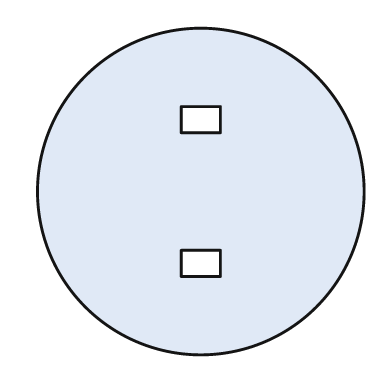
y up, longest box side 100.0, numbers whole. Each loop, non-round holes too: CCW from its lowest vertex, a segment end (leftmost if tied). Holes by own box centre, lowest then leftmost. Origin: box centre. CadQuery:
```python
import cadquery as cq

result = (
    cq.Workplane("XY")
    .moveTo(0.0, 0.0)
    .circle(50.0)
    .moveTo(-6.0, -26.0)
    .lineTo(6.0, -26.0)
    .lineTo(6.0, -18.0)
    .lineTo(-6.0, -18.0)
    .close()
    .moveTo(-6.0, 18.0)
    .lineTo(6.0, 18.0)
    .lineTo(6.0, 26.0)
    .lineTo(-6.0, 26.0)
    .close()
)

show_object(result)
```